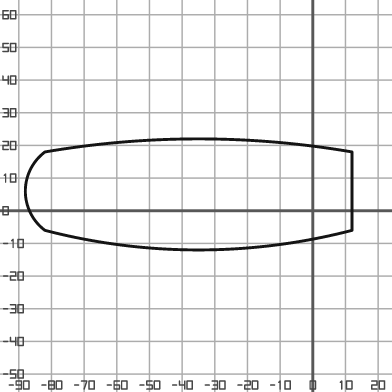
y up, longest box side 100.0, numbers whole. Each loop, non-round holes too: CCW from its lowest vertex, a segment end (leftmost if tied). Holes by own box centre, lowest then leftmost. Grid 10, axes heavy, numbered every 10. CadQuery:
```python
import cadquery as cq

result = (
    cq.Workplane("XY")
    .moveTo(-82.0, -6.0)
    .threePointArc((-35.0, -12.0), (12.0, -6.0))
    .lineTo(12.0, 18.0)
    .threePointArc((-35.0, 22.0), (-82.0, 18.0))
    .threePointArc((-88.0, 6.0), (-82.0, -6.0))
    .close()
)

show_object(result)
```